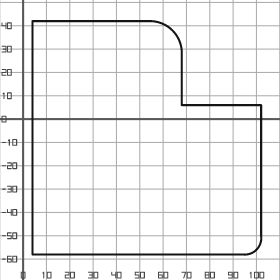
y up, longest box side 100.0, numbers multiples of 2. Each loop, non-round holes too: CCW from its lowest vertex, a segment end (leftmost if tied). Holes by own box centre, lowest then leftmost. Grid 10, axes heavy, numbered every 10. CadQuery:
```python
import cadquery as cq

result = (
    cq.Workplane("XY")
    .moveTo(4.0, -58.0)
    .lineTo(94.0, -58.0)
    .threePointArc((100.0, -56.0), (102.0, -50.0))
    .lineTo(102.0, 6.0)
    .lineTo(68.0, 6.0)
    .lineTo(68.0, 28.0)
    .threePointArc((64.0, 38.0), (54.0, 42.0))
    .lineTo(4.0, 42.0)
    .close()
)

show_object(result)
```